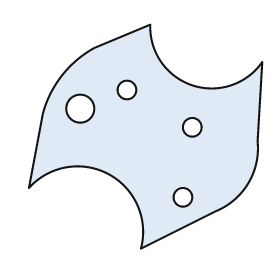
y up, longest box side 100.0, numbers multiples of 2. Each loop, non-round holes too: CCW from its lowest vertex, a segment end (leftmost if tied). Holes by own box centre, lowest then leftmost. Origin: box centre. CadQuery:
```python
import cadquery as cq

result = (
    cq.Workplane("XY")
    .moveTo(-2.0, -48.0)
    .lineTo(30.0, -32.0)
    .threePointArc((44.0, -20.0), (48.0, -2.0))
    .lineTo(50.0, 32.0)
    .threePointArc((20.0, 22.0), (2.0, 48.0))
    .lineTo(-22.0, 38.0)
    .threePointArc((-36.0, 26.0), (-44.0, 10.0))
    .lineTo(-50.0, -22.0)
    .threePointArc((-16.0, -16.0), (-2.0, -48.0))
    .close()
    .moveTo(16.0, -26.0)
    .circle(4.0)
    .moveTo(20.0, 4.0)
    .circle(4.0)
    .moveTo(-28.0, 12.0)
    .circle(6.0)
    .moveTo(-8.0, 20.0)
    .circle(4.0)
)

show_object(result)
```